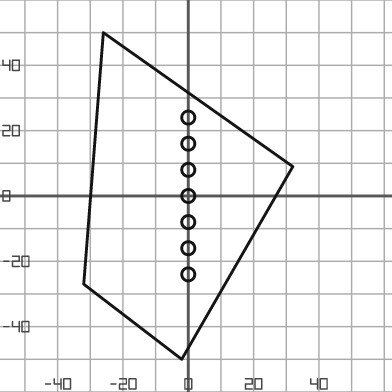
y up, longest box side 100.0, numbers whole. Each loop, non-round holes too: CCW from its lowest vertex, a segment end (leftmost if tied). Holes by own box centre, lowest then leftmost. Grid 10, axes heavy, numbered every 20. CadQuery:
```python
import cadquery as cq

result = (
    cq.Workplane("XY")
    .moveTo(-2.0, -50.0)
    .lineTo(32.0, 9.0)
    .lineTo(-26.0, 50.0)
    .lineTo(-32.0, -27.0)
    .close()
    .moveTo(0.0, -24.0)
    .circle(2.0)
    .moveTo(0.0, -16.0)
    .circle(2.0)
    .moveTo(0.0, -8.0)
    .circle(2.0)
    .moveTo(0.0, 0.0)
    .circle(2.0)
    .moveTo(0.0, 8.0)
    .circle(2.0)
    .moveTo(0.0, 16.0)
    .circle(2.0)
    .moveTo(0.0, 24.0)
    .circle(2.0)
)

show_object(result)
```